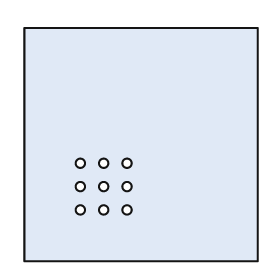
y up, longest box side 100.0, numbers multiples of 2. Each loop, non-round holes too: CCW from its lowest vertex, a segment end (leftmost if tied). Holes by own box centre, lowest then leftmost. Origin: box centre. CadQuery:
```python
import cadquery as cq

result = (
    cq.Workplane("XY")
    .moveTo(-50.0, -50.0)
    .lineTo(50.0, -50.0)
    .lineTo(50.0, 50.0)
    .lineTo(-50.0, 50.0)
    .close()
    .moveTo(-26.0, -28.0)
    .circle(2.0)
    .moveTo(-16.0, -28.0)
    .circle(2.0)
    .moveTo(-6.0, -28.0)
    .circle(2.0)
    .moveTo(-26.0, -18.0)
    .circle(2.0)
    .moveTo(-16.0, -18.0)
    .circle(2.0)
    .moveTo(-6.0, -18.0)
    .circle(2.0)
    .moveTo(-26.0, -8.0)
    .circle(2.0)
    .moveTo(-16.0, -8.0)
    .circle(2.0)
    .moveTo(-6.0, -8.0)
    .circle(2.0)
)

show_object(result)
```